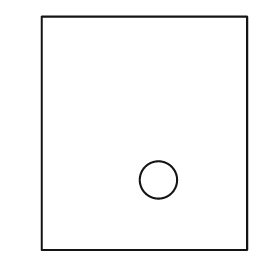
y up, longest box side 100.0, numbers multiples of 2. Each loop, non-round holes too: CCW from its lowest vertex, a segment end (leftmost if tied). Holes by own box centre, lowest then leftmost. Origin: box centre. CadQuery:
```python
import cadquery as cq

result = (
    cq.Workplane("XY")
    .moveTo(-44.0, -50.0)
    .lineTo(44.0, -50.0)
    .lineTo(44.0, 50.0)
    .lineTo(-44.0, 50.0)
    .close()
    .moveTo(6.0, -20.0)
    .circle(8.0)
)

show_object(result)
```